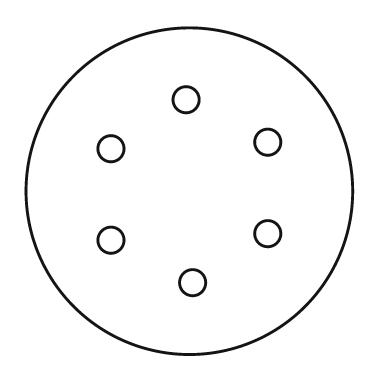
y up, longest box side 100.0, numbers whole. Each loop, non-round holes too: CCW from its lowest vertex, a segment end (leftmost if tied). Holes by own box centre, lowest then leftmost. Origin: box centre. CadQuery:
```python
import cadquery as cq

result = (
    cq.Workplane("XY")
    .moveTo(0.0, 0.0)
    .circle(50.0)
    .moveTo(1.0, -28.0)
    .circle(4.0)
    .moveTo(-24.0, -15.0)
    .circle(4.0)
    .moveTo(24.0, -13.0)
    .circle(4.0)
    .moveTo(-24.0, 13.0)
    .circle(4.0)
    .moveTo(24.0, 15.0)
    .circle(4.0)
    .moveTo(-1.0, 28.0)
    .circle(4.0)
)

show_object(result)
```